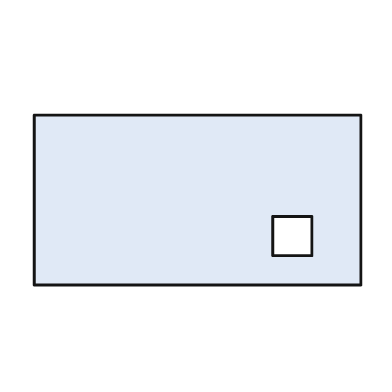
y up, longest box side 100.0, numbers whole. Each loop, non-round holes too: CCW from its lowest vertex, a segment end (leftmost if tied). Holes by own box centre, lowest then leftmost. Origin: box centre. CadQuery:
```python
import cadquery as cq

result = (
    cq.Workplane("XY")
    .moveTo(-50.0, -26.0)
    .lineTo(50.0, -26.0)
    .lineTo(50.0, 26.0)
    .lineTo(-50.0, 26.0)
    .close()
    .moveTo(23.0, -17.0)
    .lineTo(35.0, -17.0)
    .lineTo(35.0, -5.0)
    .lineTo(23.0, -5.0)
    .close()
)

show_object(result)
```